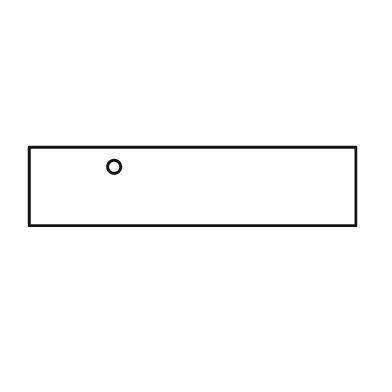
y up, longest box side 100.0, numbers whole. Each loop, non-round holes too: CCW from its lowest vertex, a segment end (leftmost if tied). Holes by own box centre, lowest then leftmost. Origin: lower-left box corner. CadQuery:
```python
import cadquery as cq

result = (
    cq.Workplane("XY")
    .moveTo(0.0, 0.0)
    .lineTo(100.0, 0.0)
    .lineTo(100.0, 24.0)
    .lineTo(0.0, 24.0)
    .close()
    .moveTo(26.0, 18.0)
    .circle(2.0)
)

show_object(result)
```